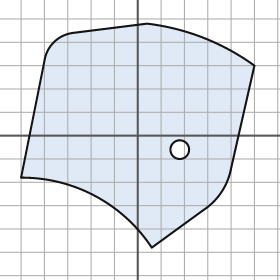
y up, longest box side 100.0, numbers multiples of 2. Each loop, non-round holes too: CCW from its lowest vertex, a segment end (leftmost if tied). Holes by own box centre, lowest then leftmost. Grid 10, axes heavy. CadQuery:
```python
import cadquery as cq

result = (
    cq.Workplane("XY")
    .moveTo(6.0, -48.0)
    .lineTo(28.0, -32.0)
    .threePointArc((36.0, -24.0), (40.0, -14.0))
    .lineTo(50.0, 30.0)
    .threePointArc((28.0, 42.0), (4.0, 48.0))
    .lineTo(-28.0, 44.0)
    .threePointArc((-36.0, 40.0), (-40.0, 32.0))
    .lineTo(-50.0, -18.0)
    .threePointArc((-18.0, -26.0), (6.0, -48.0))
    .close()
    .moveTo(18.0, -6.0)
    .circle(4.0)
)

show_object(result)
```